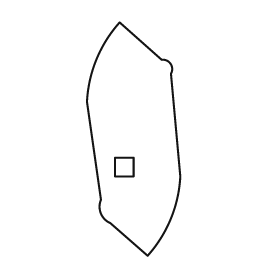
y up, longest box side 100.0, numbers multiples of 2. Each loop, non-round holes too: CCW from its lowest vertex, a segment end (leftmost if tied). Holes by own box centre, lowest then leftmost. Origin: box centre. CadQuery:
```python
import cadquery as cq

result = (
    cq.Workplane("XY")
    .moveTo(6.0, -50.0)
    .threePointArc((16.0, -34.0), (20.0, -16.0))
    .lineTo(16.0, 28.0)
    .threePointArc((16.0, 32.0), (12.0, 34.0))
    .lineTo(-6.0, 50.0)
    .threePointArc((-16.0, 34.0), (-20.0, 16.0))
    .lineTo(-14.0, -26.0)
    .threePointArc((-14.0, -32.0), (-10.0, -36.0))
    .close()
    .moveTo(-8.0, -16.0)
    .lineTo(0.0, -16.0)
    .lineTo(0.0, -8.0)
    .lineTo(-8.0, -8.0)
    .close()
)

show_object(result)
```